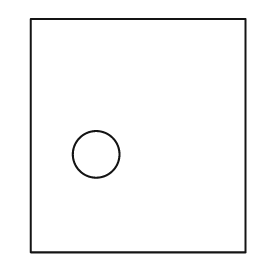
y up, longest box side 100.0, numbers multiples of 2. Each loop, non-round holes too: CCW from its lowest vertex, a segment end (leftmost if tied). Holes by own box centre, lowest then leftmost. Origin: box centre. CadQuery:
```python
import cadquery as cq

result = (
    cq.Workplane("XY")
    .moveTo(-46.0, -50.0)
    .lineTo(46.0, -50.0)
    .lineTo(46.0, 50.0)
    .lineTo(-46.0, 50.0)
    .close()
    .moveTo(-18.0, -8.0)
    .circle(10.0)
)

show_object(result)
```